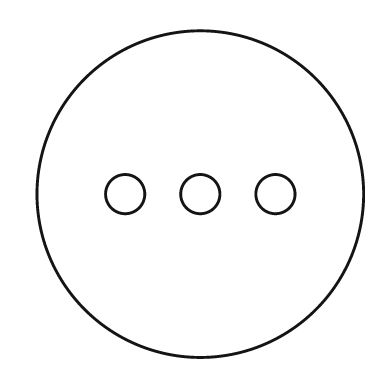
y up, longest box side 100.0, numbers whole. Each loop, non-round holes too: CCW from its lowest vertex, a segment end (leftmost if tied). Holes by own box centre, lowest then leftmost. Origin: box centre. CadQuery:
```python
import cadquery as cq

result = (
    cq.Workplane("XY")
    .moveTo(0.0, 0.0)
    .circle(50.0)
    .moveTo(-23.0, 0.0)
    .circle(6.0)
    .moveTo(0.0, 0.0)
    .circle(6.0)
    .moveTo(23.0, 0.0)
    .circle(6.0)
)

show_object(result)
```